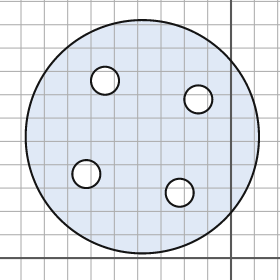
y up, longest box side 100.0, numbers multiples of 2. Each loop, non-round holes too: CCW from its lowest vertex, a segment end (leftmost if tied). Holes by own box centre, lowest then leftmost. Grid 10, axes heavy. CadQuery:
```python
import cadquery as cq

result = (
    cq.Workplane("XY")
    .moveTo(-38.0, 52.0)
    .circle(50.0)
    .moveTo(-22.0, 28.0)
    .circle(6.0)
    .moveTo(-62.0, 36.0)
    .circle(6.0)
    .moveTo(-14.0, 68.0)
    .circle(6.0)
    .moveTo(-54.0, 76.0)
    .circle(6.0)
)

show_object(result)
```